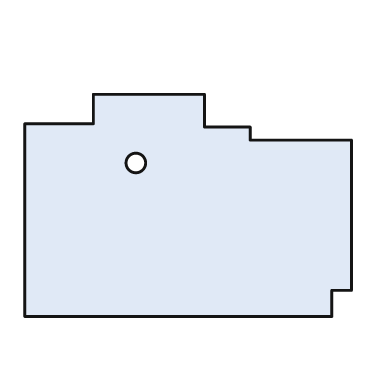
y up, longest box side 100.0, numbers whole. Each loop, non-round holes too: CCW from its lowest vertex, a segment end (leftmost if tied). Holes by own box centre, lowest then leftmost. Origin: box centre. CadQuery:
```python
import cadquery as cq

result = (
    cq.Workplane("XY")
    .moveTo(-50.0, -34.0)
    .lineTo(44.0, -34.0)
    .lineTo(44.0, -26.0)
    .lineTo(50.0, -26.0)
    .lineTo(50.0, 20.0)
    .lineTo(19.0, 20.0)
    .lineTo(19.0, 24.0)
    .lineTo(5.0, 24.0)
    .lineTo(5.0, 34.0)
    .lineTo(-29.0, 34.0)
    .lineTo(-29.0, 25.0)
    .lineTo(-50.0, 25.0)
    .close()
    .moveTo(-16.0, 13.0)
    .circle(3.0)
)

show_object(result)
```